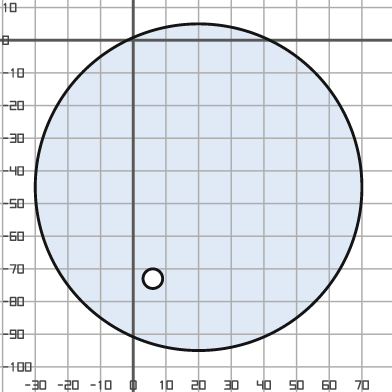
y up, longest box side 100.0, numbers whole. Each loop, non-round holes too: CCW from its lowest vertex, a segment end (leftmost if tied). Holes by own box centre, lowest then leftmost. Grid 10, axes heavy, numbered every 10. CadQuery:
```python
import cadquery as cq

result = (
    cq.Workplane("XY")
    .moveTo(20.0, -45.0)
    .circle(50.0)
    .moveTo(6.0, -73.0)
    .circle(3.0)
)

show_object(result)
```